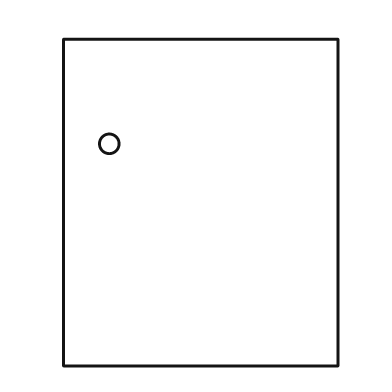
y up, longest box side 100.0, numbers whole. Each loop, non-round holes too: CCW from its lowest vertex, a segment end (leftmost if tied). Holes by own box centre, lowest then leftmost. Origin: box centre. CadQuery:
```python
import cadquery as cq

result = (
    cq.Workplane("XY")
    .moveTo(-42.0, -50.0)
    .lineTo(42.0, -50.0)
    .lineTo(42.0, 50.0)
    .lineTo(-42.0, 50.0)
    .close()
    .moveTo(-28.0, 18.0)
    .circle(3.0)
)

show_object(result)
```